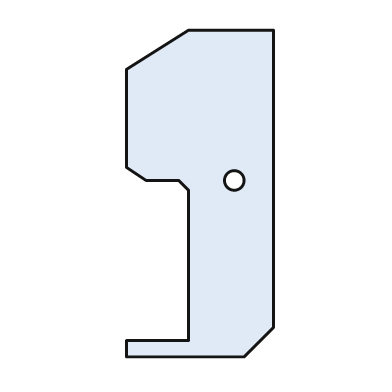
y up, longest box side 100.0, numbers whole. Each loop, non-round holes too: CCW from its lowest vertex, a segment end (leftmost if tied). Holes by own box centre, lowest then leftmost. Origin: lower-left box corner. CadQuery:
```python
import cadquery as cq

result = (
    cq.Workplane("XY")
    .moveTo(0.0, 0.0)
    .lineTo(36.0, 0.0)
    .lineTo(45.0, 9.0)
    .lineTo(45.0, 100.0)
    .lineTo(19.0, 100.0)
    .lineTo(0.0, 88.0)
    .lineTo(0.0, 58.0)
    .lineTo(6.0, 54.0)
    .lineTo(16.0, 54.0)
    .lineTo(19.0, 51.0)
    .lineTo(19.0, 5.0)
    .lineTo(0.0, 5.0)
    .close()
    .moveTo(33.0, 54.0)
    .circle(3.0)
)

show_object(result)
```